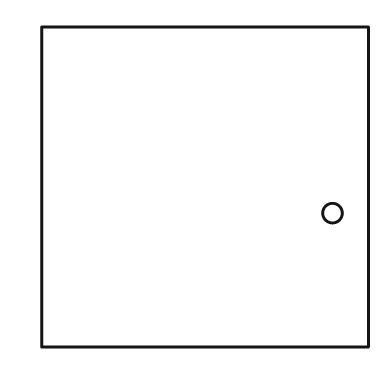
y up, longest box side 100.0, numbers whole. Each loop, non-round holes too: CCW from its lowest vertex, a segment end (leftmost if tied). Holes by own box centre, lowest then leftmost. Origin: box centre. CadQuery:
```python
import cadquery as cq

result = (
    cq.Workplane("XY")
    .moveTo(-50.0, -49.0)
    .lineTo(50.0, -49.0)
    .lineTo(50.0, 49.0)
    .lineTo(-50.0, 49.0)
    .close()
    .moveTo(39.0, -8.0)
    .circle(3.0)
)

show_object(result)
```